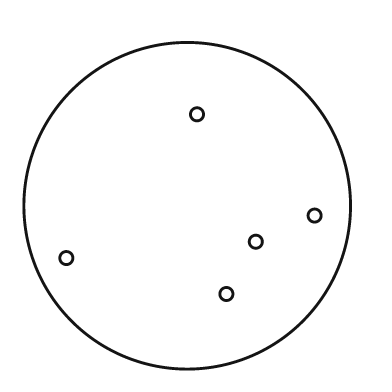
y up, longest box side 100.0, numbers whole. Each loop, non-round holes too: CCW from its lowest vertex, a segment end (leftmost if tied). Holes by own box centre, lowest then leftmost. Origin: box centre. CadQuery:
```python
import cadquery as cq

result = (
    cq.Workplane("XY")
    .moveTo(0.0, 0.0)
    .circle(50.0)
    .moveTo(12.0, -27.0)
    .circle(2.0)
    .moveTo(-37.0, -16.0)
    .circle(2.0)
    .moveTo(21.0, -11.0)
    .circle(2.0)
    .moveTo(39.0, -3.0)
    .circle(2.0)
    .moveTo(3.0, 28.0)
    .circle(2.0)
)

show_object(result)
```